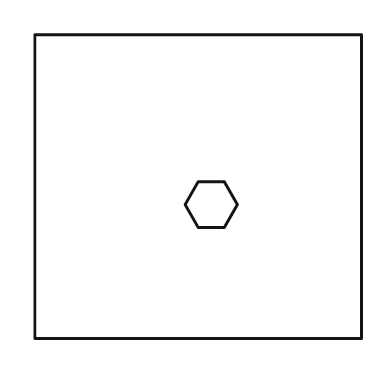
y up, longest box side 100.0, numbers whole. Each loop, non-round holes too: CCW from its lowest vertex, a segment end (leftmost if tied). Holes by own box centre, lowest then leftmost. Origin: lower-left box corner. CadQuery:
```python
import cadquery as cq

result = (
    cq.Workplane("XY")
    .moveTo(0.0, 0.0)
    .lineTo(100.0, 0.0)
    .lineTo(100.0, 93.0)
    .lineTo(0.0, 93.0)
    .close()
    .moveTo(50.0, 34.0)
    .lineTo(58.0, 34.0)
    .lineTo(62.0, 41.0)
    .lineTo(58.0, 48.0)
    .lineTo(50.0, 48.0)
    .lineTo(46.0, 41.0)
    .close()
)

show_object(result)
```